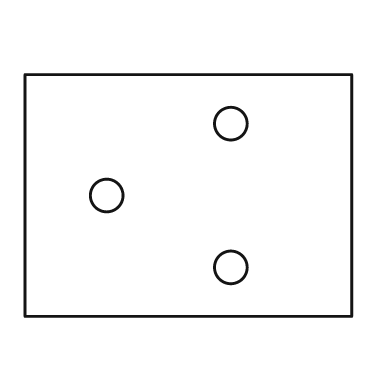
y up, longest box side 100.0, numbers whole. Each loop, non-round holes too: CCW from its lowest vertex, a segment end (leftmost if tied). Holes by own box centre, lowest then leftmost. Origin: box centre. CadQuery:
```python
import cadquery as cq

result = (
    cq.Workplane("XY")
    .moveTo(-50.0, -37.0)
    .lineTo(50.0, -37.0)
    .lineTo(50.0, 37.0)
    .lineTo(-50.0, 37.0)
    .close()
    .moveTo(13.0, -22.0)
    .circle(5.0)
    .moveTo(-25.0, 0.0)
    .circle(5.0)
    .moveTo(13.0, 22.0)
    .circle(5.0)
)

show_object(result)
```